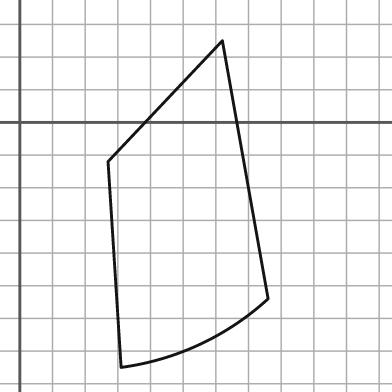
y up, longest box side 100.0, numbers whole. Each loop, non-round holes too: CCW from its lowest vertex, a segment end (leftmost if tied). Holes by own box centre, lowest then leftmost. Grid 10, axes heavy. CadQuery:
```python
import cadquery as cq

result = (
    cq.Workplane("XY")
    .moveTo(31.0, -75.0)
    .threePointArc((55.0, -68.0), (76.0, -54.0))
    .lineTo(62.0, 25.0)
    .lineTo(27.0, -12.0)
    .close()
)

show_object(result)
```